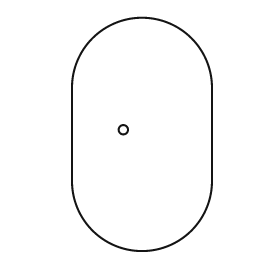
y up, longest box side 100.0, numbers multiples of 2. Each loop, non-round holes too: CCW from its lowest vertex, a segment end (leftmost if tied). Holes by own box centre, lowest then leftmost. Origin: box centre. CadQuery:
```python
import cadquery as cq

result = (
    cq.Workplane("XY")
    .moveTo(-30.0, -20.0)
    .threePointArc((0.0, -50.0), (30.0, -20.0))
    .lineTo(30.0, 20.0)
    .threePointArc((0.0, 50.0), (-30.0, 20.0))
    .close()
    .moveTo(-8.0, 2.0)
    .circle(2.0)
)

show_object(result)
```